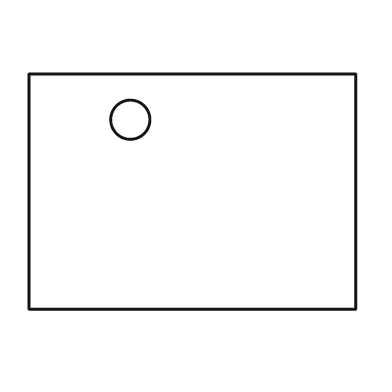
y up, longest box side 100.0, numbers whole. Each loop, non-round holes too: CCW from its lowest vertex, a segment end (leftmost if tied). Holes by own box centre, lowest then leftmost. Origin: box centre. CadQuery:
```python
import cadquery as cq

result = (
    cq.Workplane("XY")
    .moveTo(-50.0, -36.0)
    .lineTo(50.0, -36.0)
    .lineTo(50.0, 36.0)
    .lineTo(-50.0, 36.0)
    .close()
    .moveTo(-19.0, 22.0)
    .circle(6.0)
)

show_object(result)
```